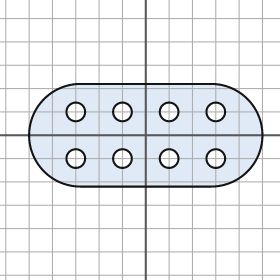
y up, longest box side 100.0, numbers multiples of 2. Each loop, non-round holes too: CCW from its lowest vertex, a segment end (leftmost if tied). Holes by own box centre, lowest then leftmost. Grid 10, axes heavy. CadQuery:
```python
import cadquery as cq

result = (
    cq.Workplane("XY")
    .moveTo(-28.0, -22.0)
    .lineTo(28.0, -22.0)
    .threePointArc((50.0, 0.0), (28.0, 22.0))
    .lineTo(-28.0, 22.0)
    .threePointArc((-50.0, 0.0), (-28.0, -22.0))
    .close()
    .moveTo(-30.0, -10.0)
    .circle(4.0)
    .moveTo(-10.0, -10.0)
    .circle(4.0)
    .moveTo(10.0, -10.0)
    .circle(4.0)
    .moveTo(30.0, -10.0)
    .circle(4.0)
    .moveTo(-30.0, 10.0)
    .circle(4.0)
    .moveTo(-10.0, 10.0)
    .circle(4.0)
    .moveTo(10.0, 10.0)
    .circle(4.0)
    .moveTo(30.0, 10.0)
    .circle(4.0)
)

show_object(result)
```